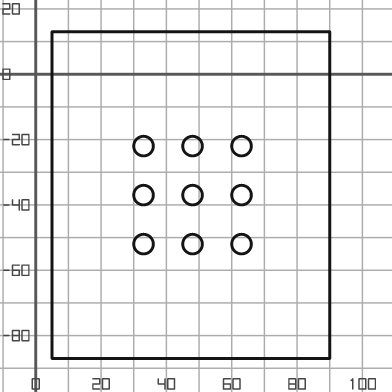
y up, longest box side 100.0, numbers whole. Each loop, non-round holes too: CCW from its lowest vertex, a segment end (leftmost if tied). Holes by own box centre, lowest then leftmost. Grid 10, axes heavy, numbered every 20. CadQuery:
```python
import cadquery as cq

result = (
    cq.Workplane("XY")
    .moveTo(5.0, -87.0)
    .lineTo(90.0, -87.0)
    .lineTo(90.0, 13.0)
    .lineTo(5.0, 13.0)
    .close()
    .moveTo(33.0, -52.0)
    .circle(3.0)
    .moveTo(48.0, -52.0)
    .circle(3.0)
    .moveTo(63.0, -52.0)
    .circle(3.0)
    .moveTo(33.0, -37.0)
    .circle(3.0)
    .moveTo(48.0, -37.0)
    .circle(3.0)
    .moveTo(63.0, -37.0)
    .circle(3.0)
    .moveTo(33.0, -22.0)
    .circle(3.0)
    .moveTo(48.0, -22.0)
    .circle(3.0)
    .moveTo(63.0, -22.0)
    .circle(3.0)
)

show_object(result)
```